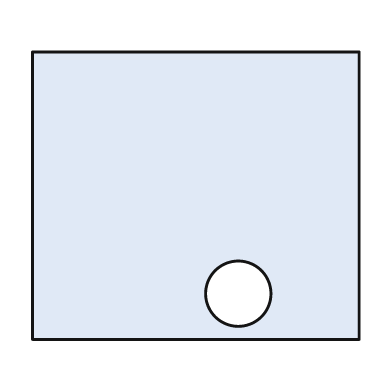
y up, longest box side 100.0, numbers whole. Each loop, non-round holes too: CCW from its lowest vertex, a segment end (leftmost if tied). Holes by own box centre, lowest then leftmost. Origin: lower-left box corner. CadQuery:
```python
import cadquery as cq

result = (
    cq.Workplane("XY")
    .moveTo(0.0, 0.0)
    .lineTo(100.0, 0.0)
    .lineTo(100.0, 88.0)
    .lineTo(0.0, 88.0)
    .close()
    .moveTo(63.0, 14.0)
    .circle(10.0)
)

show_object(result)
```